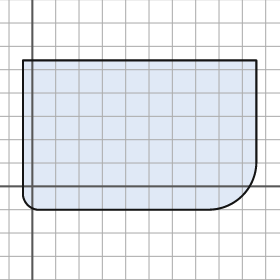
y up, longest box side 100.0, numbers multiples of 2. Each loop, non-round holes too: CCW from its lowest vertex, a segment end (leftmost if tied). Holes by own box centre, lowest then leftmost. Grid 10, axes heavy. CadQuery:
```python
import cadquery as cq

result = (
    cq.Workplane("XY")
    .moveTo(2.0, -10.0)
    .lineTo(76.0, -10.0)
    .threePointArc((90.0, -4.0), (96.0, 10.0))
    .lineTo(96.0, 54.0)
    .lineTo(-4.0, 54.0)
    .lineTo(-4.0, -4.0)
    .threePointArc((-2.0, -8.0), (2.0, -10.0))
    .close()
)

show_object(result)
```